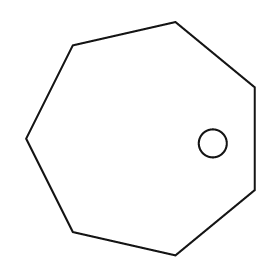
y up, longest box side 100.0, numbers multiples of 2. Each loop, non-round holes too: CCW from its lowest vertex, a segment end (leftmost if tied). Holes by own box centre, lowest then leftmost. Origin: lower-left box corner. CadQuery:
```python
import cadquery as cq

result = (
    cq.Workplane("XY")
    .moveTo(64.0, 0.0)
    .lineTo(98.0, 28.0)
    .lineTo(98.0, 72.0)
    .lineTo(64.0, 100.0)
    .lineTo(20.0, 90.0)
    .lineTo(0.0, 50.0)
    .lineTo(20.0, 10.0)
    .close()
    .moveTo(80.0, 48.0)
    .circle(6.0)
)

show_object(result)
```